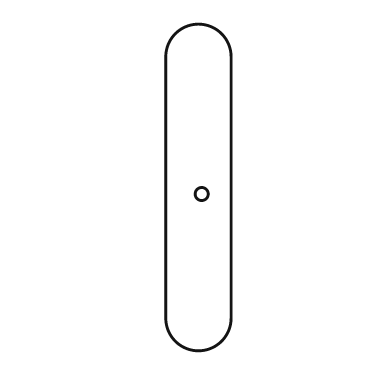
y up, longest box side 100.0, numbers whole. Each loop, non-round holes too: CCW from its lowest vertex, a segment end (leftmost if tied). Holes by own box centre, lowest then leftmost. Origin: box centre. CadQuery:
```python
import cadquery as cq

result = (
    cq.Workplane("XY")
    .moveTo(-10.0, -40.0)
    .threePointArc((0.0, -50.0), (10.0, -40.0))
    .lineTo(10.0, 40.0)
    .threePointArc((0.0, 50.0), (-10.0, 40.0))
    .close()
    .moveTo(1.0, -2.0)
    .circle(2.0)
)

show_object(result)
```